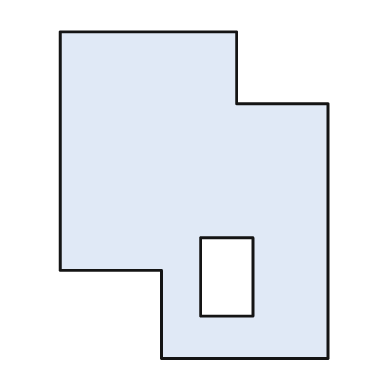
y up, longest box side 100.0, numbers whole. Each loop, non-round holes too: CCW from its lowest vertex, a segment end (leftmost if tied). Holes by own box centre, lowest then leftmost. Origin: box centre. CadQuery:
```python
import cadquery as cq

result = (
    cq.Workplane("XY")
    .moveTo(-10.0, -50.0)
    .lineTo(41.0, -50.0)
    .lineTo(41.0, 28.0)
    .lineTo(13.0, 28.0)
    .lineTo(13.0, 50.0)
    .lineTo(-41.0, 50.0)
    .lineTo(-41.0, -23.0)
    .lineTo(-10.0, -23.0)
    .close()
    .moveTo(2.0, -37.0)
    .lineTo(18.0, -37.0)
    .lineTo(18.0, -13.0)
    .lineTo(2.0, -13.0)
    .close()
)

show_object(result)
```